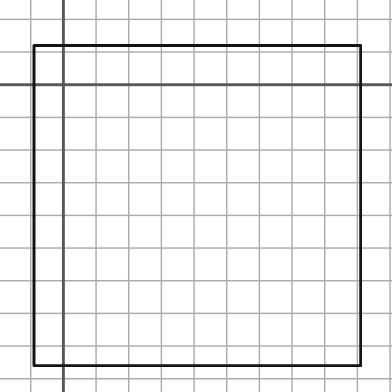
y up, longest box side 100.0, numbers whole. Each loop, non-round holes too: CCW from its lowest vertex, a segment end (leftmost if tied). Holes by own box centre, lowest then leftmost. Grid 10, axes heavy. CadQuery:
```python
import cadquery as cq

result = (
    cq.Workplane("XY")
    .moveTo(-9.0, -86.0)
    .lineTo(91.0, -86.0)
    .lineTo(91.0, 12.0)
    .lineTo(-9.0, 12.0)
    .close()
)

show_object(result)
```